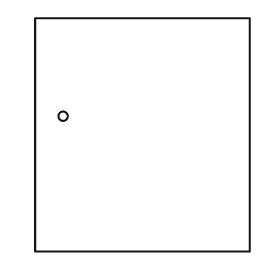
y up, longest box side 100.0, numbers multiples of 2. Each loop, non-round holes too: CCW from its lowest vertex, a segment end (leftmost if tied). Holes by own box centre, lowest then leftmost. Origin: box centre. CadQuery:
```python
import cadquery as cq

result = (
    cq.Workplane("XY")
    .moveTo(-46.0, -50.0)
    .lineTo(46.0, -50.0)
    .lineTo(46.0, 50.0)
    .lineTo(-46.0, 50.0)
    .close()
    .moveTo(-34.0, 8.0)
    .circle(2.0)
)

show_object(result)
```